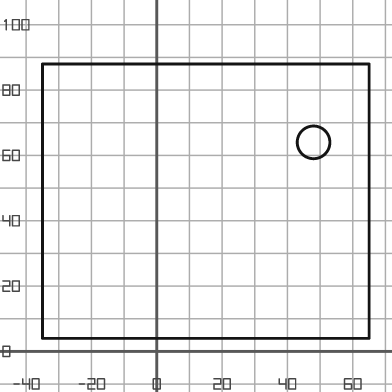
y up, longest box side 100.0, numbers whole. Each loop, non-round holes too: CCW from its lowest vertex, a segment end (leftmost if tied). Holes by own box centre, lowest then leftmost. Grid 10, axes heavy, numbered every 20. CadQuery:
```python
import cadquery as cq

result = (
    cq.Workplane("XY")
    .moveTo(-35.0, 4.0)
    .lineTo(65.0, 4.0)
    .lineTo(65.0, 88.0)
    .lineTo(-35.0, 88.0)
    .close()
    .moveTo(48.0, 64.0)
    .circle(5.0)
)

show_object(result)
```